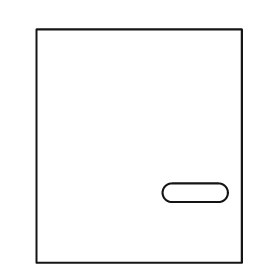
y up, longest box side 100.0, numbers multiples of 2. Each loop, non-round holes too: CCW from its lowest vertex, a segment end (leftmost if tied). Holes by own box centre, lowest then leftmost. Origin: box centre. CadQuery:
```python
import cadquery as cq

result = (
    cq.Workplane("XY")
    .moveTo(-44.0, -50.0)
    .lineTo(44.0, -50.0)
    .lineTo(44.0, 50.0)
    .lineTo(-44.0, 50.0)
    .close()
    .moveTo(14.0, -24.0)
    .lineTo(34.0, -24.0)
    .threePointArc((38.0, -20.0), (34.0, -16.0))
    .lineTo(14.0, -16.0)
    .threePointArc((10.0, -20.0), (14.0, -24.0))
    .close()
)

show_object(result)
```